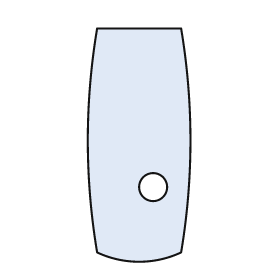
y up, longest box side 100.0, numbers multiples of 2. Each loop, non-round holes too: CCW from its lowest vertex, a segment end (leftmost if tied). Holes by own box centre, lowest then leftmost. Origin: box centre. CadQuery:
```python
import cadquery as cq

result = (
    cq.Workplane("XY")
    .moveTo(-18.0, -46.0)
    .threePointArc((0.0, -50.0), (18.0, -46.0))
    .threePointArc((22.0, 2.0), (18.0, 50.0))
    .lineTo(-18.0, 50.0)
    .threePointArc((-22.0, 2.0), (-18.0, -46.0))
    .close()
    .moveTo(6.0, -18.0)
    .circle(6.0)
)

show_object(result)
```